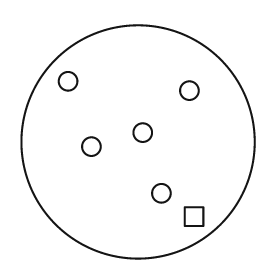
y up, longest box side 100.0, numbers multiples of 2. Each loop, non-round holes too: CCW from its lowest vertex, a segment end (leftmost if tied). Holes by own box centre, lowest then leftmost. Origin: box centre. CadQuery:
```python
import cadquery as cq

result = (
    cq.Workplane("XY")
    .moveTo(0.0, 0.0)
    .circle(50.0)
    .moveTo(20.0, -36.0)
    .lineTo(28.0, -36.0)
    .lineTo(28.0, -28.0)
    .lineTo(20.0, -28.0)
    .close()
    .moveTo(10.0, -22.0)
    .circle(4.0)
    .moveTo(-20.0, -2.0)
    .circle(4.0)
    .moveTo(2.0, 4.0)
    .circle(4.0)
    .moveTo(22.0, 22.0)
    .circle(4.0)
    .moveTo(-30.0, 26.0)
    .circle(4.0)
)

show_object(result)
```